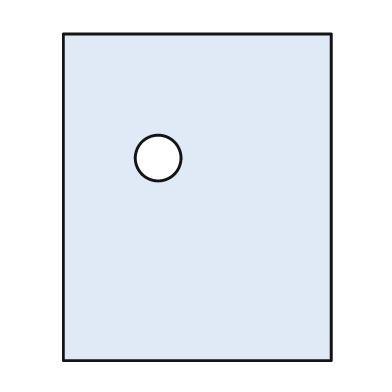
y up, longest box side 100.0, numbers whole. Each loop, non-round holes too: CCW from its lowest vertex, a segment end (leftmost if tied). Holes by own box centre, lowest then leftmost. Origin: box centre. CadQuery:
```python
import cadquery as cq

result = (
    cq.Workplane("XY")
    .moveTo(-41.0, -50.0)
    .lineTo(41.0, -50.0)
    .lineTo(41.0, 50.0)
    .lineTo(-41.0, 50.0)
    .close()
    .moveTo(-12.0, 12.0)
    .circle(7.0)
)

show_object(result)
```